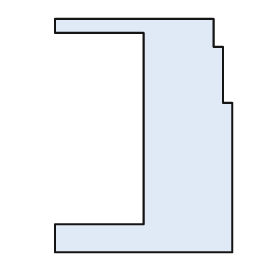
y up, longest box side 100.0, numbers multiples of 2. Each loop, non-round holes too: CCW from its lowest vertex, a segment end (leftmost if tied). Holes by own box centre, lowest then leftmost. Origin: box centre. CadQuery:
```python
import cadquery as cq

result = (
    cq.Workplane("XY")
    .moveTo(-38.0, -50.0)
    .lineTo(38.0, -50.0)
    .lineTo(38.0, 14.0)
    .lineTo(34.0, 14.0)
    .lineTo(34.0, 38.0)
    .lineTo(30.0, 38.0)
    .lineTo(30.0, 50.0)
    .lineTo(-38.0, 50.0)
    .lineTo(-38.0, 44.0)
    .lineTo(0.0, 44.0)
    .lineTo(0.0, -38.0)
    .lineTo(-38.0, -38.0)
    .close()
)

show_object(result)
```